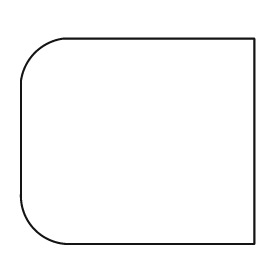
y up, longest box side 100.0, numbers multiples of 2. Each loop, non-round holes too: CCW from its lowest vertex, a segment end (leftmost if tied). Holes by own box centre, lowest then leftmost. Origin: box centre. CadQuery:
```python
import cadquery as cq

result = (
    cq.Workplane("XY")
    .moveTo(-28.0, -44.0)
    .lineTo(50.0, -44.0)
    .lineTo(50.0, 44.0)
    .lineTo(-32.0, 44.0)
    .threePointArc((-44.0, 38.0), (-50.0, 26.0))
    .lineTo(-50.0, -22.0)
    .threePointArc((-44.0, -38.0), (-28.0, -44.0))
    .close()
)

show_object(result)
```